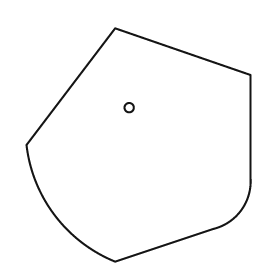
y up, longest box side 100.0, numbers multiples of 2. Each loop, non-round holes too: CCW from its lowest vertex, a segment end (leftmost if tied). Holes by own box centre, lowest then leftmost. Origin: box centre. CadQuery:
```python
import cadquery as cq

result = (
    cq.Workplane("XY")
    .moveTo(-10.0, -50.0)
    .lineTo(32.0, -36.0)
    .threePointArc((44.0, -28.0), (48.0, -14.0))
    .lineTo(48.0, 30.0)
    .lineTo(-10.0, 50.0)
    .lineTo(-48.0, 0.0)
    .threePointArc((-36.0, -30.0), (-10.0, -50.0))
    .close()
    .moveTo(-4.0, 16.0)
    .circle(2.0)
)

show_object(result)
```